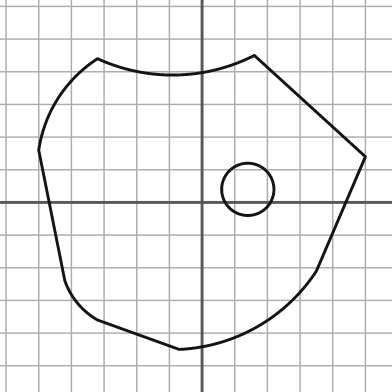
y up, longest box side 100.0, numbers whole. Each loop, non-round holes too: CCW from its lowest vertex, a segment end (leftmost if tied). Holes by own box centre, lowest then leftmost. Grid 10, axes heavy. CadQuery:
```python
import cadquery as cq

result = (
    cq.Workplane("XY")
    .moveTo(-7.0, -45.0)
    .threePointArc((17.0, -38.0), (35.0, -21.0))
    .lineTo(50.0, 14.0)
    .lineTo(16.0, 45.0)
    .threePointArc((-8.0, 39.0), (-32.0, 44.0))
    .threePointArc((-44.0, 32.0), (-50.0, 16.0))
    .lineTo(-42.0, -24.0)
    .threePointArc((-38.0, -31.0), (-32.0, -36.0))
    .close()
    .moveTo(14.0, 4.0)
    .circle(8.0)
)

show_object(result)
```